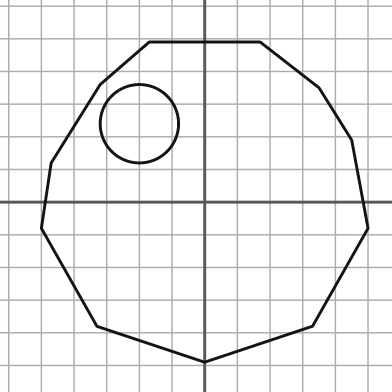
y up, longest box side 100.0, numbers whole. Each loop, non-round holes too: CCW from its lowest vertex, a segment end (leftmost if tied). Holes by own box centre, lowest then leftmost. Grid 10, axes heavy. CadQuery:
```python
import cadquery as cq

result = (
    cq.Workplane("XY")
    .moveTo(0.0, -49.0)
    .lineTo(33.0, -38.0)
    .lineTo(50.0, -8.0)
    .lineTo(45.0, 19.0)
    .lineTo(35.0, 35.0)
    .lineTo(17.0, 49.0)
    .lineTo(-17.0, 49.0)
    .lineTo(-32.0, 36.0)
    .lineTo(-47.0, 12.0)
    .lineTo(-50.0, -8.0)
    .lineTo(-33.0, -38.0)
    .close()
    .moveTo(-20.0, 24.0)
    .circle(12.0)
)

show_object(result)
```